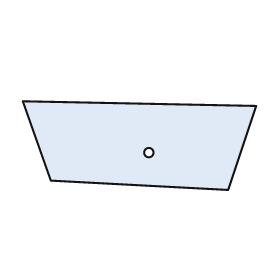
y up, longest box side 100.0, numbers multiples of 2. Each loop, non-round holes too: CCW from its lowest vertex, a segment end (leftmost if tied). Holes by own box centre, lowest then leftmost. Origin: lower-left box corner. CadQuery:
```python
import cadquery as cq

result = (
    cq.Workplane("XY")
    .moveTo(88.0, 0.0)
    .lineTo(100.0, 36.0)
    .lineTo(0.0, 38.0)
    .lineTo(12.0, 4.0)
    .close()
    .moveTo(54.0, 16.0)
    .circle(2.0)
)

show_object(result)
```